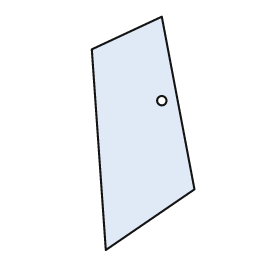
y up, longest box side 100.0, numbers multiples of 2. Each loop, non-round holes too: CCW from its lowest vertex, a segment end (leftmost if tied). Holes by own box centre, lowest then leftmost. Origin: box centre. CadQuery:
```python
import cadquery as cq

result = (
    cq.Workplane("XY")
    .moveTo(-16.0, -50.0)
    .lineTo(22.0, -24.0)
    .lineTo(8.0, 50.0)
    .lineTo(-22.0, 36.0)
    .close()
    .moveTo(8.0, 14.0)
    .circle(2.0)
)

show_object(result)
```